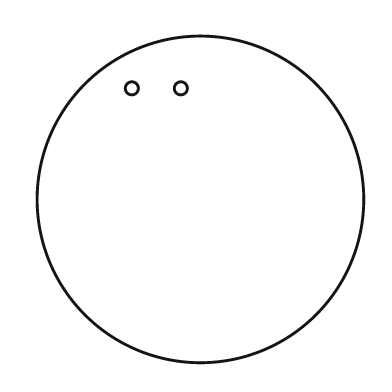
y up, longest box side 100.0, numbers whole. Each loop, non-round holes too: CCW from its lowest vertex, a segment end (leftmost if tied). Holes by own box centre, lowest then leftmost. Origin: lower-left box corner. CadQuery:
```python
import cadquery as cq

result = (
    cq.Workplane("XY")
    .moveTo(50.0, 50.0)
    .circle(50.0)
    .moveTo(29.0, 84.0)
    .circle(2.0)
    .moveTo(44.0, 84.0)
    .circle(2.0)
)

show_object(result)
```